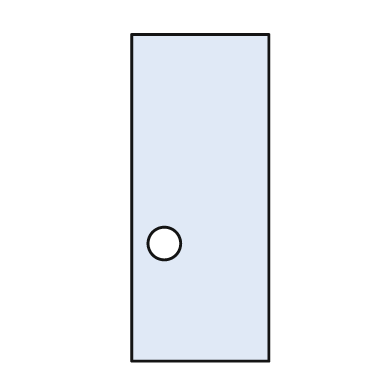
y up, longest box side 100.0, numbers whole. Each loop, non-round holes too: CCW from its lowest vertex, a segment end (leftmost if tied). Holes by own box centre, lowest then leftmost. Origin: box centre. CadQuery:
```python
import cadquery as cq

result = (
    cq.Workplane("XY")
    .moveTo(-21.0, -50.0)
    .lineTo(21.0, -50.0)
    .lineTo(21.0, 50.0)
    .lineTo(-21.0, 50.0)
    .close()
    .moveTo(-11.0, -14.0)
    .circle(5.0)
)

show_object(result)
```